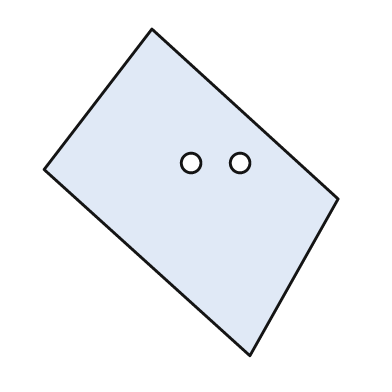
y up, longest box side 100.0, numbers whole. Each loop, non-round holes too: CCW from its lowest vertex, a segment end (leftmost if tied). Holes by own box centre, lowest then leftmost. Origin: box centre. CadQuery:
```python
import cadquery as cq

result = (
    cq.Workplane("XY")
    .moveTo(18.0, -50.0)
    .lineTo(45.0, -2.0)
    .lineTo(-12.0, 50.0)
    .lineTo(-45.0, 7.0)
    .close()
    .moveTo(0.0, 9.0)
    .circle(3.0)
    .moveTo(15.0, 9.0)
    .circle(3.0)
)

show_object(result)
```